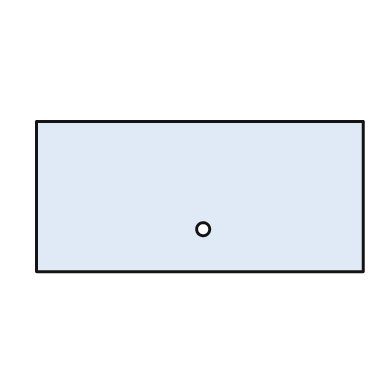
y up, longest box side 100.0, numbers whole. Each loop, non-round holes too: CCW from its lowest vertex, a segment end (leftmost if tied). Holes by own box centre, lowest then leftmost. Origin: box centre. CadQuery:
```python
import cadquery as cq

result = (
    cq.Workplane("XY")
    .moveTo(-50.0, -23.0)
    .lineTo(50.0, -23.0)
    .lineTo(50.0, 23.0)
    .lineTo(-50.0, 23.0)
    .close()
    .moveTo(1.0, -10.0)
    .circle(2.0)
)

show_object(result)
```